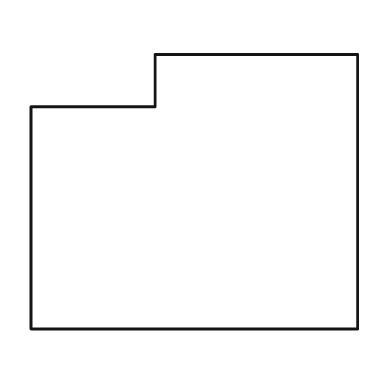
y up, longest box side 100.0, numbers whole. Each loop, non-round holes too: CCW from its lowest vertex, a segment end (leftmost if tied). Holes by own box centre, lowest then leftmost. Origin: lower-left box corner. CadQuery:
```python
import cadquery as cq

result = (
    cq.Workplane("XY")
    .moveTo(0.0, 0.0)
    .lineTo(100.0, 0.0)
    .lineTo(100.0, 84.0)
    .lineTo(38.0, 84.0)
    .lineTo(38.0, 68.0)
    .lineTo(0.0, 68.0)
    .close()
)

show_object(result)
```